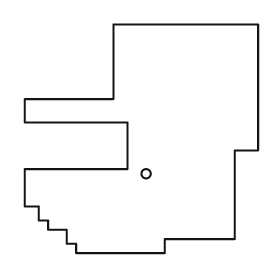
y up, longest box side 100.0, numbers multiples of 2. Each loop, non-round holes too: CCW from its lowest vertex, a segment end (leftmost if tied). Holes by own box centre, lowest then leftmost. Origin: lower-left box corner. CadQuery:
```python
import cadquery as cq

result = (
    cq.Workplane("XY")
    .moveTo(22.0, 0.0)
    .lineTo(60.0, 0.0)
    .lineTo(60.0, 6.0)
    .lineTo(90.0, 6.0)
    .lineTo(90.0, 44.0)
    .lineTo(100.0, 44.0)
    .lineTo(100.0, 98.0)
    .lineTo(38.0, 98.0)
    .lineTo(38.0, 66.0)
    .lineTo(0.0, 66.0)
    .lineTo(0.0, 56.0)
    .lineTo(44.0, 56.0)
    .lineTo(44.0, 36.0)
    .lineTo(0.0, 36.0)
    .lineTo(0.0, 20.0)
    .lineTo(6.0, 20.0)
    .lineTo(6.0, 14.0)
    .lineTo(10.0, 14.0)
    .lineTo(10.0, 10.0)
    .lineTo(18.0, 10.0)
    .lineTo(18.0, 4.0)
    .lineTo(22.0, 4.0)
    .close()
    .moveTo(52.0, 34.0)
    .circle(2.0)
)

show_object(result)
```